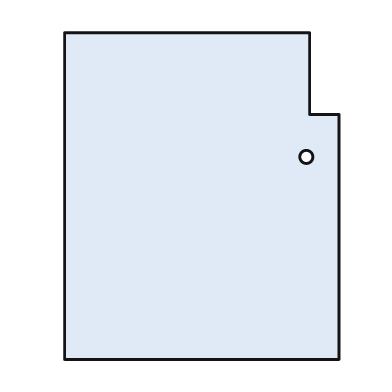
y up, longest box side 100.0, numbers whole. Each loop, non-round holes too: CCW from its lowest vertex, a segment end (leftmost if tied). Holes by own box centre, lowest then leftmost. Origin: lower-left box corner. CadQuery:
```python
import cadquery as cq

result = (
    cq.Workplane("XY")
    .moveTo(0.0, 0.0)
    .lineTo(84.0, 0.0)
    .lineTo(84.0, 75.0)
    .lineTo(75.0, 75.0)
    .lineTo(75.0, 100.0)
    .lineTo(0.0, 100.0)
    .close()
    .moveTo(74.0, 62.0)
    .circle(2.0)
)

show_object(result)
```